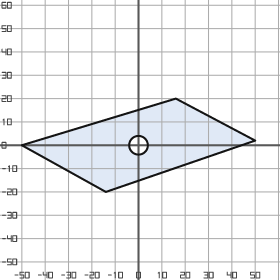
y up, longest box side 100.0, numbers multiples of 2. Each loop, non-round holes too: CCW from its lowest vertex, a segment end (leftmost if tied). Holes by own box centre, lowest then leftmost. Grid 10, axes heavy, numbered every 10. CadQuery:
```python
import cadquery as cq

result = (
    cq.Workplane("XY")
    .moveTo(-14.0, -20.0)
    .lineTo(50.0, 2.0)
    .lineTo(16.0, 20.0)
    .lineTo(-50.0, 0.0)
    .close()
    .moveTo(0.0, 0.0)
    .circle(4.0)
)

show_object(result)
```